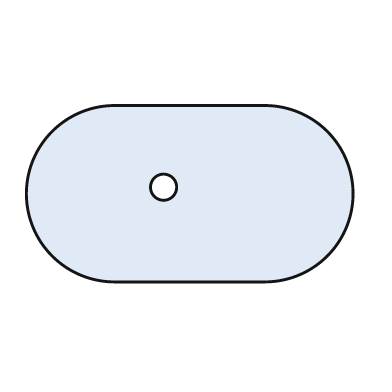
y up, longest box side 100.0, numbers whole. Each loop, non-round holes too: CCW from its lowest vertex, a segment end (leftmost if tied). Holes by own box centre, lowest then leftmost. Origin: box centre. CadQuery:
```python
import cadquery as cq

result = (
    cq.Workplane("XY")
    .moveTo(-23.0, -27.0)
    .lineTo(23.0, -27.0)
    .threePointArc((50.0, 0.0), (23.0, 27.0))
    .lineTo(-23.0, 27.0)
    .threePointArc((-50.0, 0.0), (-23.0, -27.0))
    .close()
    .moveTo(-8.0, 2.0)
    .circle(4.0)
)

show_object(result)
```